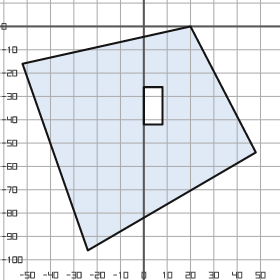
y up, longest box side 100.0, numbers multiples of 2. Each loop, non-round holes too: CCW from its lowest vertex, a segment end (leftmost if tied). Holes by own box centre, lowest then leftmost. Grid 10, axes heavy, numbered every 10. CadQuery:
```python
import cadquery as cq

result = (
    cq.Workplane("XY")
    .moveTo(-24.0, -96.0)
    .lineTo(48.0, -54.0)
    .lineTo(20.0, 0.0)
    .lineTo(-52.0, -16.0)
    .close()
    .moveTo(0.0, -42.0)
    .lineTo(8.0, -42.0)
    .lineTo(8.0, -26.0)
    .lineTo(0.0, -26.0)
    .close()
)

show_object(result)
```